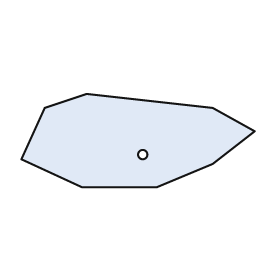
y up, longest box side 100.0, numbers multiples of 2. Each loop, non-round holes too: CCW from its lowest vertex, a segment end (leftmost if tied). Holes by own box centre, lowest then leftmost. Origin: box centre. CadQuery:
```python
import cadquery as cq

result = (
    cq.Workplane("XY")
    .moveTo(-24.0, -20.0)
    .lineTo(8.0, -20.0)
    .lineTo(32.0, -10.0)
    .lineTo(50.0, 4.0)
    .lineTo(32.0, 14.0)
    .lineTo(-22.0, 20.0)
    .lineTo(-40.0, 14.0)
    .lineTo(-50.0, -8.0)
    .close()
    .moveTo(2.0, -6.0)
    .circle(2.0)
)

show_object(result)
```